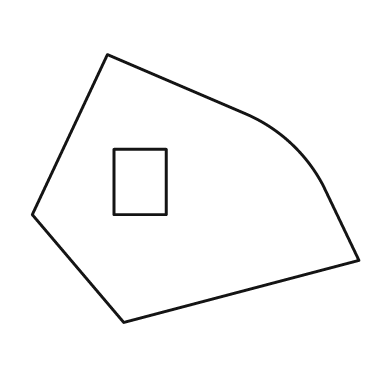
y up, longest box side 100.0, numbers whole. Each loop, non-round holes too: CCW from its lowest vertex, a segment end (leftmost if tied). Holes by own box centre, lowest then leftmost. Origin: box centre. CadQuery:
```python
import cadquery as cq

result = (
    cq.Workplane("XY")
    .moveTo(-22.0, -41.0)
    .lineTo(50.0, -22.0)
    .lineTo(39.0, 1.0)
    .threePointArc((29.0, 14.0), (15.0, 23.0))
    .lineTo(-27.0, 41.0)
    .lineTo(-50.0, -8.0)
    .close()
    .moveTo(-25.0, -8.0)
    .lineTo(-9.0, -8.0)
    .lineTo(-9.0, 12.0)
    .lineTo(-25.0, 12.0)
    .close()
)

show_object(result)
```